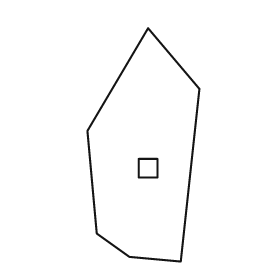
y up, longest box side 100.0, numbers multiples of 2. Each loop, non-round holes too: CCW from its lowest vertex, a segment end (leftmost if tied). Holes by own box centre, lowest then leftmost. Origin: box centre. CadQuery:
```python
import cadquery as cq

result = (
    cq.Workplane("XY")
    .moveTo(16.0, -50.0)
    .lineTo(24.0, 24.0)
    .lineTo(2.0, 50.0)
    .lineTo(-24.0, 6.0)
    .lineTo(-20.0, -38.0)
    .lineTo(-6.0, -48.0)
    .close()
    .moveTo(-2.0, -14.0)
    .lineTo(6.0, -14.0)
    .lineTo(6.0, -6.0)
    .lineTo(-2.0, -6.0)
    .close()
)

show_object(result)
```